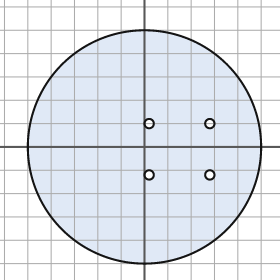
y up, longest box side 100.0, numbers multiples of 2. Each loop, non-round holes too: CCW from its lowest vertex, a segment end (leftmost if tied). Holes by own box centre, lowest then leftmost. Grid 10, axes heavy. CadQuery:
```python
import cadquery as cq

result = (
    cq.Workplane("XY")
    .moveTo(0.0, 0.0)
    .circle(50.0)
    .moveTo(2.0, -12.0)
    .circle(2.0)
    .moveTo(28.0, -12.0)
    .circle(2.0)
    .moveTo(2.0, 10.0)
    .circle(2.0)
    .moveTo(28.0, 10.0)
    .circle(2.0)
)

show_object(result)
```